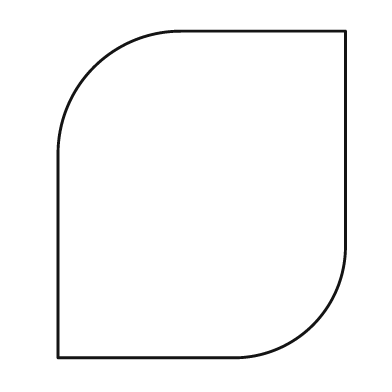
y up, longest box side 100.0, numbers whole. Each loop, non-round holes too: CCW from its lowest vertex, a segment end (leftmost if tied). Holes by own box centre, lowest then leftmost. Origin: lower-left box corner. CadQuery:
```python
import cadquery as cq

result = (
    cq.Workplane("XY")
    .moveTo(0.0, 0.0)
    .lineTo(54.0, 0.0)
    .threePointArc((78.0, 10.0), (88.0, 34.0))
    .lineTo(88.0, 100.0)
    .lineTo(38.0, 100.0)
    .threePointArc((11.0, 89.0), (0.0, 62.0))
    .close()
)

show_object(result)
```